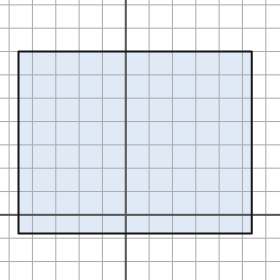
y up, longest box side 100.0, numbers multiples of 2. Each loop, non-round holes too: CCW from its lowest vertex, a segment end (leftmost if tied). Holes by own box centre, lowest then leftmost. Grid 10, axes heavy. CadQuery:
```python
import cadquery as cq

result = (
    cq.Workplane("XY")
    .moveTo(-46.0, -8.0)
    .lineTo(54.0, -8.0)
    .lineTo(54.0, 70.0)
    .lineTo(-46.0, 70.0)
    .close()
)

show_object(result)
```